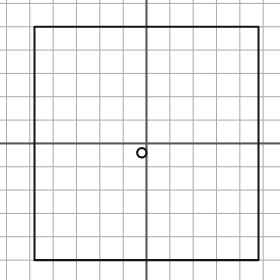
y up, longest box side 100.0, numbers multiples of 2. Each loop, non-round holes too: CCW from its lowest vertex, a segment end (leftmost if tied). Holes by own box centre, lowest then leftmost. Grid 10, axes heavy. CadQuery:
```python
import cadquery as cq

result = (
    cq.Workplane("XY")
    .moveTo(-48.0, -50.0)
    .lineTo(48.0, -50.0)
    .lineTo(48.0, 50.0)
    .lineTo(-48.0, 50.0)
    .close()
    .moveTo(-2.0, -4.0)
    .circle(2.0)
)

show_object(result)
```